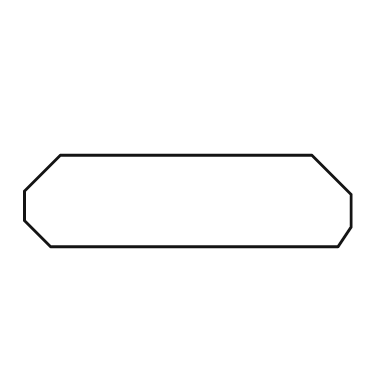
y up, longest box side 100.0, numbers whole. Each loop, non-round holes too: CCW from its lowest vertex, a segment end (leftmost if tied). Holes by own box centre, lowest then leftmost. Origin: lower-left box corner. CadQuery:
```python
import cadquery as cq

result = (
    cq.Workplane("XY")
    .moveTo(8.0, 0.0)
    .lineTo(96.0, 0.0)
    .lineTo(100.0, 6.0)
    .lineTo(100.0, 16.0)
    .lineTo(88.0, 28.0)
    .lineTo(11.0, 28.0)
    .lineTo(0.0, 17.0)
    .lineTo(0.0, 8.0)
    .close()
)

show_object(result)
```